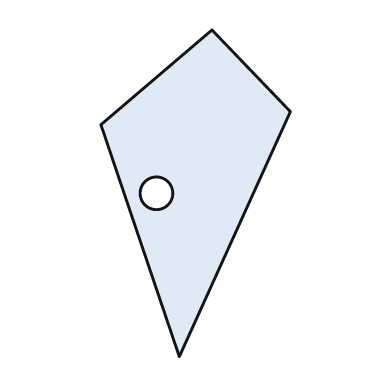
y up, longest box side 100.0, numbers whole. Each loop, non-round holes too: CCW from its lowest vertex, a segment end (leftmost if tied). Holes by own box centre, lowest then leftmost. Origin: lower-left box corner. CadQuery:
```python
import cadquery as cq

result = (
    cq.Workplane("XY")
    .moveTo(24.0, 0.0)
    .lineTo(58.0, 75.0)
    .lineTo(34.0, 100.0)
    .lineTo(0.0, 71.0)
    .close()
    .moveTo(17.0, 50.0)
    .circle(5.0)
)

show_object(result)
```